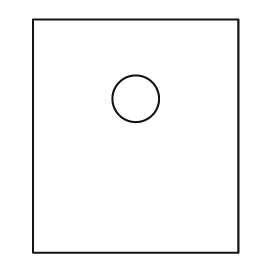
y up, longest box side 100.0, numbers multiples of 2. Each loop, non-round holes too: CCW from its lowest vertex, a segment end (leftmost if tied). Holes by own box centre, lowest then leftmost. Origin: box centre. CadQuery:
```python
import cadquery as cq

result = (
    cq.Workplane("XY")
    .moveTo(-44.0, -50.0)
    .lineTo(44.0, -50.0)
    .lineTo(44.0, 50.0)
    .lineTo(-44.0, 50.0)
    .close()
    .moveTo(0.0, 16.0)
    .circle(10.0)
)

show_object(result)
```